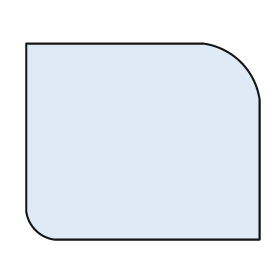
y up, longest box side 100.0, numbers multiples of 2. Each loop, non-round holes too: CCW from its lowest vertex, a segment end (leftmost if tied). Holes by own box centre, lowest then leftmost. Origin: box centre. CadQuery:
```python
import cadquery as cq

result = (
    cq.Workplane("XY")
    .moveTo(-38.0, -42.0)
    .lineTo(50.0, -42.0)
    .lineTo(50.0, 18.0)
    .threePointArc((42.0, 34.0), (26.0, 42.0))
    .lineTo(-50.0, 42.0)
    .lineTo(-50.0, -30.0)
    .threePointArc((-46.0, -38.0), (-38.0, -42.0))
    .close()
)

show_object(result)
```